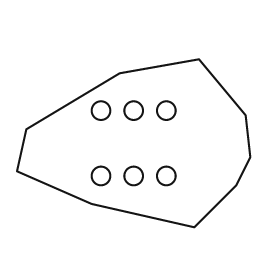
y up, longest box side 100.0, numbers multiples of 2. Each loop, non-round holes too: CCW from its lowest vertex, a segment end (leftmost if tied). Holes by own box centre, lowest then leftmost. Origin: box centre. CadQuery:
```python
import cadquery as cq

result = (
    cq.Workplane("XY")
    .moveTo(26.0, -36.0)
    .lineTo(44.0, -18.0)
    .lineTo(50.0, -6.0)
    .lineTo(48.0, 12.0)
    .lineTo(28.0, 36.0)
    .lineTo(-6.0, 30.0)
    .lineTo(-46.0, 6.0)
    .lineTo(-50.0, -12.0)
    .lineTo(-18.0, -26.0)
    .close()
    .moveTo(-14.0, -14.0)
    .circle(4.0)
    .moveTo(0.0, -14.0)
    .circle(4.0)
    .moveTo(14.0, -14.0)
    .circle(4.0)
    .moveTo(-14.0, 14.0)
    .circle(4.0)
    .moveTo(0.0, 14.0)
    .circle(4.0)
    .moveTo(14.0, 14.0)
    .circle(4.0)
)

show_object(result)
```